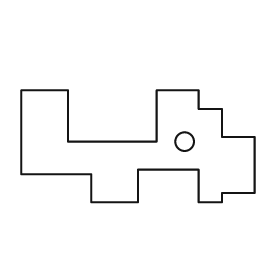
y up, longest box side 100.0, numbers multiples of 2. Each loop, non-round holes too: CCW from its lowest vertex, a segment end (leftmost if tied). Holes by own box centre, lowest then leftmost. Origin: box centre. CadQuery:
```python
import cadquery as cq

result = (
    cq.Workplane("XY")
    .moveTo(-20.0, -24.0)
    .lineTo(0.0, -24.0)
    .lineTo(0.0, -10.0)
    .lineTo(26.0, -10.0)
    .lineTo(26.0, -24.0)
    .lineTo(36.0, -24.0)
    .lineTo(36.0, -20.0)
    .lineTo(50.0, -20.0)
    .lineTo(50.0, 4.0)
    .lineTo(36.0, 4.0)
    .lineTo(36.0, 16.0)
    .lineTo(26.0, 16.0)
    .lineTo(26.0, 24.0)
    .lineTo(8.0, 24.0)
    .lineTo(8.0, 2.0)
    .lineTo(-30.0, 2.0)
    .lineTo(-30.0, 24.0)
    .lineTo(-50.0, 24.0)
    .lineTo(-50.0, -12.0)
    .lineTo(-20.0, -12.0)
    .close()
    .moveTo(20.0, 2.0)
    .circle(4.0)
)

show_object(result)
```